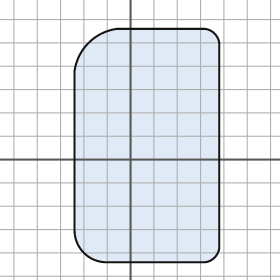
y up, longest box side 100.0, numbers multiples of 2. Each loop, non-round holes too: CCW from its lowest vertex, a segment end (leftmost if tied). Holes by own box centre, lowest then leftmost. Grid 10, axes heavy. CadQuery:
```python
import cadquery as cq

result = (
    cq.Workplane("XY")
    .moveTo(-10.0, -44.0)
    .lineTo(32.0, -44.0)
    .threePointArc((36.0, -42.0), (38.0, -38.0))
    .lineTo(38.0, 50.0)
    .threePointArc((36.0, 54.0), (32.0, 56.0))
    .lineTo(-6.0, 56.0)
    .threePointArc((-18.0, 50.0), (-24.0, 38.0))
    .lineTo(-24.0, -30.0)
    .threePointArc((-20.0, -40.0), (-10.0, -44.0))
    .close()
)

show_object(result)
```